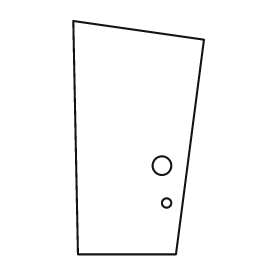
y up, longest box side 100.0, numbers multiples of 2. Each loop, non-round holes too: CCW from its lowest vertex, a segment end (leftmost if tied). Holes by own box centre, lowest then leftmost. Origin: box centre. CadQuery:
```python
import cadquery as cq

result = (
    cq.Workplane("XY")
    .moveTo(-26.0, -50.0)
    .lineTo(16.0, -50.0)
    .lineTo(28.0, 42.0)
    .lineTo(-28.0, 50.0)
    .close()
    .moveTo(12.0, -28.0)
    .circle(2.0)
    .moveTo(10.0, -12.0)
    .circle(4.0)
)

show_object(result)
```